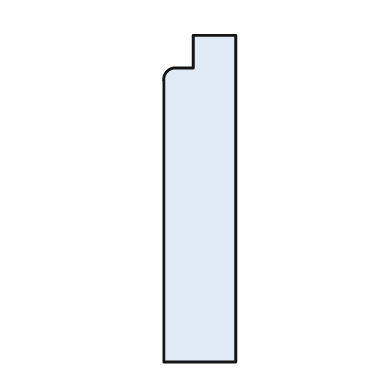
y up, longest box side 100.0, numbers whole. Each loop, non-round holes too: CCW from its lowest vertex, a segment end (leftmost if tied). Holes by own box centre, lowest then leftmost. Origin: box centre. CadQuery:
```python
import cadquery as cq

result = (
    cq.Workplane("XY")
    .moveTo(-11.0, -50.0)
    .lineTo(11.0, -50.0)
    .lineTo(11.0, 50.0)
    .lineTo(-2.0, 50.0)
    .lineTo(-2.0, 40.0)
    .lineTo(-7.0, 40.0)
    .threePointArc((-10.0, 39.0), (-11.0, 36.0))
    .close()
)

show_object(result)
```